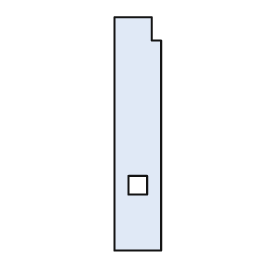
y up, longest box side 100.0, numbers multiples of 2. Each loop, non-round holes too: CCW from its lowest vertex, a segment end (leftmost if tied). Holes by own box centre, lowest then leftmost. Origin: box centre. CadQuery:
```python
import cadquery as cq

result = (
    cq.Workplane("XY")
    .moveTo(-10.0, -50.0)
    .lineTo(10.0, -50.0)
    .lineTo(10.0, 40.0)
    .lineTo(6.0, 40.0)
    .lineTo(6.0, 50.0)
    .lineTo(-10.0, 50.0)
    .close()
    .moveTo(-4.0, -26.0)
    .lineTo(4.0, -26.0)
    .lineTo(4.0, -18.0)
    .lineTo(-4.0, -18.0)
    .close()
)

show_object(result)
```